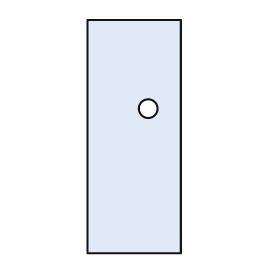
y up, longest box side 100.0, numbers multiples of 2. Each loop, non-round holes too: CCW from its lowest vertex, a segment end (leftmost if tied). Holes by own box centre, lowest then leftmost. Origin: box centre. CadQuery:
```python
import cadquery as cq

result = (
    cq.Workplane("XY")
    .moveTo(-20.0, -50.0)
    .lineTo(20.0, -50.0)
    .lineTo(20.0, 50.0)
    .lineTo(-20.0, 50.0)
    .close()
    .moveTo(6.0, 12.0)
    .circle(4.0)
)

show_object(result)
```